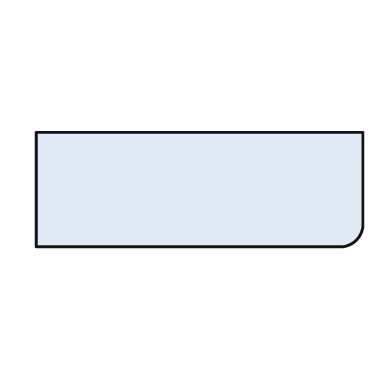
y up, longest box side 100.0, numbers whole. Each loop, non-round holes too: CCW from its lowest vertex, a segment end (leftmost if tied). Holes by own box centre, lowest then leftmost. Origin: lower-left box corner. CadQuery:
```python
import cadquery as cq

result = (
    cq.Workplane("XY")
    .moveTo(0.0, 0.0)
    .lineTo(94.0, 0.0)
    .threePointArc((98.0, 2.0), (100.0, 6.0))
    .lineTo(100.0, 35.0)
    .lineTo(0.0, 35.0)
    .close()
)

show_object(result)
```